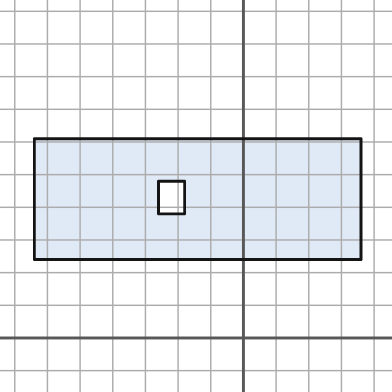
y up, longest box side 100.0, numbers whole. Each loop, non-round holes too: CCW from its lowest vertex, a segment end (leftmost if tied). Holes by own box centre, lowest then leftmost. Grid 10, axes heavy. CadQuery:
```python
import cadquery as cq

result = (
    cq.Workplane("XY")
    .moveTo(-64.0, 24.0)
    .lineTo(36.0, 24.0)
    .lineTo(36.0, 61.0)
    .lineTo(-64.0, 61.0)
    .close()
    .moveTo(-26.0, 38.0)
    .lineTo(-18.0, 38.0)
    .lineTo(-18.0, 48.0)
    .lineTo(-26.0, 48.0)
    .close()
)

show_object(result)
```